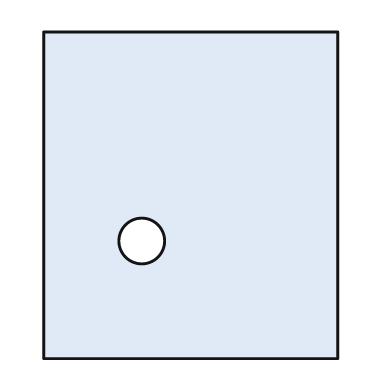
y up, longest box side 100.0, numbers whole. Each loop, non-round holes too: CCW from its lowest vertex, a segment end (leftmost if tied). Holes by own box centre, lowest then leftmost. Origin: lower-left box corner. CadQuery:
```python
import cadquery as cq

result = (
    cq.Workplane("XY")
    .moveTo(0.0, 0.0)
    .lineTo(90.0, 0.0)
    .lineTo(90.0, 100.0)
    .lineTo(0.0, 100.0)
    .close()
    .moveTo(30.0, 36.0)
    .circle(7.0)
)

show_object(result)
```